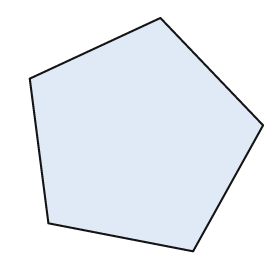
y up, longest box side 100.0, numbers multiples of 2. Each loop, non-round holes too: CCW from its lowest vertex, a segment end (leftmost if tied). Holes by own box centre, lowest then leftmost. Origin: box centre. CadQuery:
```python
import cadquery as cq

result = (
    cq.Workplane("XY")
    .moveTo(20.0, -50.0)
    .lineTo(50.0, 4.0)
    .lineTo(6.0, 50.0)
    .lineTo(-50.0, 24.0)
    .lineTo(-42.0, -38.0)
    .close()
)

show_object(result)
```